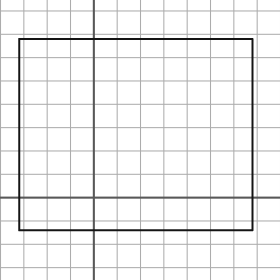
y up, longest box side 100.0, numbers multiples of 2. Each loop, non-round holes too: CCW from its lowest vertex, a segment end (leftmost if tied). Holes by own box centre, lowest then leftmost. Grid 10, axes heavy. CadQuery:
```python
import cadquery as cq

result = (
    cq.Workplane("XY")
    .moveTo(-32.0, -14.0)
    .lineTo(68.0, -14.0)
    .lineTo(68.0, 68.0)
    .lineTo(-32.0, 68.0)
    .close()
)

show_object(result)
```